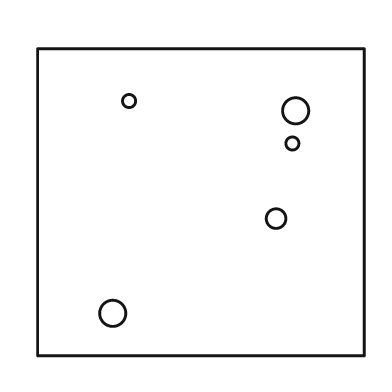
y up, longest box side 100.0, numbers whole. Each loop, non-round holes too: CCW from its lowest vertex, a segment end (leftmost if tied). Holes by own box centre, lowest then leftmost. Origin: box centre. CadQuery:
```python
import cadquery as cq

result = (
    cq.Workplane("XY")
    .moveTo(-50.0, -47.0)
    .lineTo(50.0, -47.0)
    .lineTo(50.0, 47.0)
    .lineTo(-50.0, 47.0)
    .close()
    .moveTo(-27.0, -34.0)
    .circle(4.0)
    .moveTo(23.0, -5.0)
    .circle(3.0)
    .moveTo(28.0, 18.0)
    .circle(2.0)
    .moveTo(29.0, 28.0)
    .circle(4.0)
    .moveTo(-22.0, 31.0)
    .circle(2.0)
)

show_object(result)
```